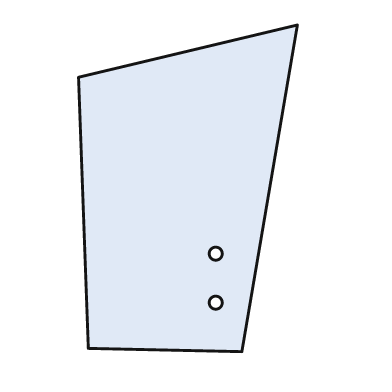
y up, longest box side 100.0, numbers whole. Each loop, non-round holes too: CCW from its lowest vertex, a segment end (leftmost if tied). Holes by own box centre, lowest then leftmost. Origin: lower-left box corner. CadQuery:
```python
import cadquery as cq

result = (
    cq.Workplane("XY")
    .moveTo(50.0, 0.0)
    .lineTo(67.0, 100.0)
    .lineTo(0.0, 84.0)
    .lineTo(3.0, 1.0)
    .close()
    .moveTo(42.0, 15.0)
    .circle(2.0)
    .moveTo(42.0, 30.0)
    .circle(2.0)
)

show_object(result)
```